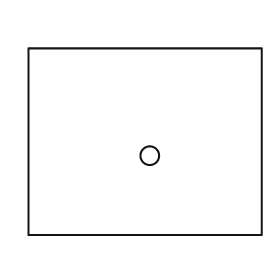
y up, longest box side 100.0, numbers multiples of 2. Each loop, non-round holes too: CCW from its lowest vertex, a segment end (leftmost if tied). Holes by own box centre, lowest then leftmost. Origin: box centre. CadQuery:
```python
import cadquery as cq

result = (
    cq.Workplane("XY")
    .moveTo(-50.0, -40.0)
    .lineTo(50.0, -40.0)
    .lineTo(50.0, 40.0)
    .lineTo(-50.0, 40.0)
    .close()
    .moveTo(2.0, -6.0)
    .circle(4.0)
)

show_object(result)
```